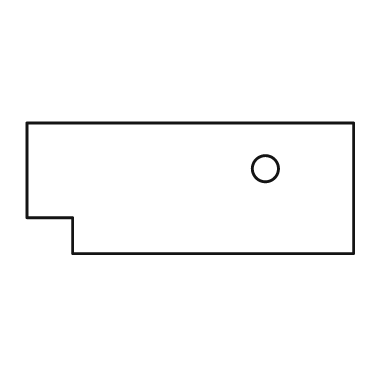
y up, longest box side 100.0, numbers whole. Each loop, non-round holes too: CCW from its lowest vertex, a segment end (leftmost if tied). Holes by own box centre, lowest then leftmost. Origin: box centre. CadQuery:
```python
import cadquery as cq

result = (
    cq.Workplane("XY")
    .moveTo(-36.0, -20.0)
    .lineTo(50.0, -20.0)
    .lineTo(50.0, 20.0)
    .lineTo(-50.0, 20.0)
    .lineTo(-50.0, -9.0)
    .lineTo(-36.0, -9.0)
    .close()
    .moveTo(23.0, 6.0)
    .circle(4.0)
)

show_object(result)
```